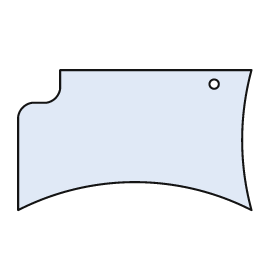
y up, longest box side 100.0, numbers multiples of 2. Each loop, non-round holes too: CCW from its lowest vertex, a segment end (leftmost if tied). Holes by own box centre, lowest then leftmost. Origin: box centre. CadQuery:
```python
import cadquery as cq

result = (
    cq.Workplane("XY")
    .moveTo(-50.0, -30.0)
    .threePointArc((0.0, -18.0), (50.0, -30.0))
    .threePointArc((46.0, 0.0), (50.0, 30.0))
    .lineTo(-32.0, 30.0)
    .lineTo(-32.0, 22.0)
    .threePointArc((-34.0, 18.0), (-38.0, 16.0))
    .lineTo(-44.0, 16.0)
    .threePointArc((-48.0, 14.0), (-50.0, 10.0))
    .close()
    .moveTo(34.0, 24.0)
    .circle(2.0)
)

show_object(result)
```